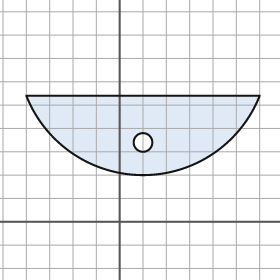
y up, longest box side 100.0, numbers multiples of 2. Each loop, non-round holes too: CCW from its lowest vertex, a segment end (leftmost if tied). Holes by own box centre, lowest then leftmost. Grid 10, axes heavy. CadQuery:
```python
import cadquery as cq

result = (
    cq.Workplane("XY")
    .moveTo(-40.0, 54.0)
    .threePointArc((10.0, 20.0), (60.0, 54.0))
    .close()
    .moveTo(10.0, 34.0)
    .circle(4.0)
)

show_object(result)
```